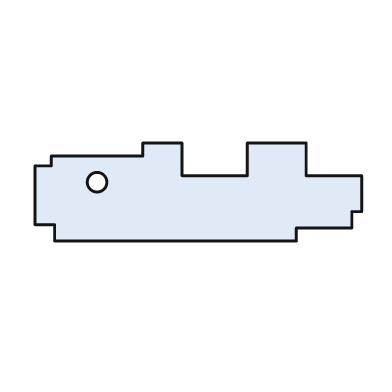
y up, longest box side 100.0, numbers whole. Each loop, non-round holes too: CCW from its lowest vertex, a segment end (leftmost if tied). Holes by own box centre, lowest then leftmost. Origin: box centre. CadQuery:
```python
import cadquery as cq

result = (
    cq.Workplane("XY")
    .moveTo(-44.0, -15.0)
    .lineTo(30.0, -15.0)
    .lineTo(30.0, -11.0)
    .lineTo(47.0, -11.0)
    .lineTo(47.0, -6.0)
    .lineTo(50.0, -6.0)
    .lineTo(50.0, 5.0)
    .lineTo(33.0, 5.0)
    .lineTo(33.0, 15.0)
    .lineTo(15.0, 15.0)
    .lineTo(15.0, 5.0)
    .lineTo(-5.0, 5.0)
    .lineTo(-5.0, 15.0)
    .lineTo(-17.0, 15.0)
    .lineTo(-17.0, 11.0)
    .lineTo(-45.0, 11.0)
    .lineTo(-45.0, 8.0)
    .lineTo(-50.0, 8.0)
    .lineTo(-50.0, -10.0)
    .lineTo(-44.0, -10.0)
    .close()
    .moveTo(-31.0, 3.0)
    .circle(3.0)
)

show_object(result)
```